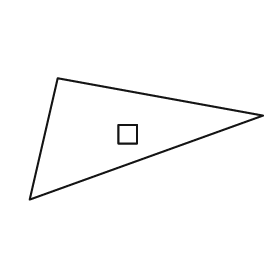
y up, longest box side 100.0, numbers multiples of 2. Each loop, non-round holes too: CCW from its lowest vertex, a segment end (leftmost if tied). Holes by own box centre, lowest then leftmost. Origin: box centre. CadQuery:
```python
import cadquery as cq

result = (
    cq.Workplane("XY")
    .moveTo(-50.0, -26.0)
    .lineTo(50.0, 10.0)
    .lineTo(-38.0, 26.0)
    .close()
    .moveTo(-12.0, -2.0)
    .lineTo(-4.0, -2.0)
    .lineTo(-4.0, 6.0)
    .lineTo(-12.0, 6.0)
    .close()
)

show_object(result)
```